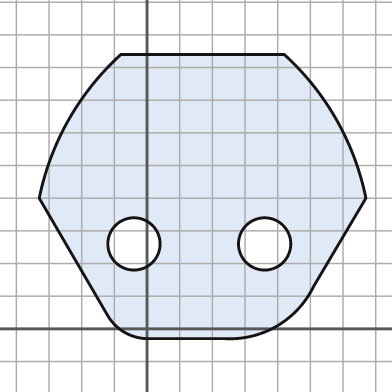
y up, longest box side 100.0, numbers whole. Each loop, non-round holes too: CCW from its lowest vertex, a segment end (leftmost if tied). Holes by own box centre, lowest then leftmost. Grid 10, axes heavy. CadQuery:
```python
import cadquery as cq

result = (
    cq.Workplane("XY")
    .moveTo(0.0, -3.0)
    .lineTo(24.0, -3.0)
    .threePointArc((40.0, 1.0), (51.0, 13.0))
    .lineTo(67.0, 40.0)
    .threePointArc((58.0, 64.0), (42.0, 84.0))
    .lineTo(-8.0, 84.0)
    .threePointArc((-24.0, 64.0), (-33.0, 40.0))
    .lineTo(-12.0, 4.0)
    .threePointArc((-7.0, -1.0), (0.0, -3.0))
    .close()
    .moveTo(-4.0, 26.0)
    .circle(8.0)
    .moveTo(36.0, 26.0)
    .circle(8.0)
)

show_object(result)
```